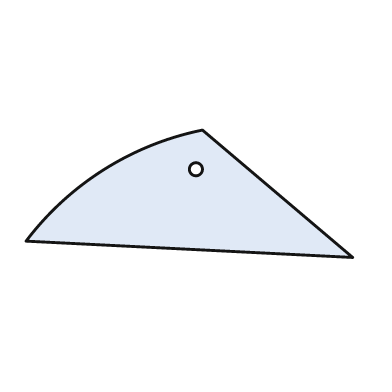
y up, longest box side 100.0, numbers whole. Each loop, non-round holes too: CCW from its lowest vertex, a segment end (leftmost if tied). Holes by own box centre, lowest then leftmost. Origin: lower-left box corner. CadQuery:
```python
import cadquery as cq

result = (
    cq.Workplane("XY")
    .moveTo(100.0, 0.0)
    .lineTo(54.0, 39.0)
    .threePointArc((24.0, 27.0), (0.0, 5.0))
    .close()
    .moveTo(52.0, 27.0)
    .circle(2.0)
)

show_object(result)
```